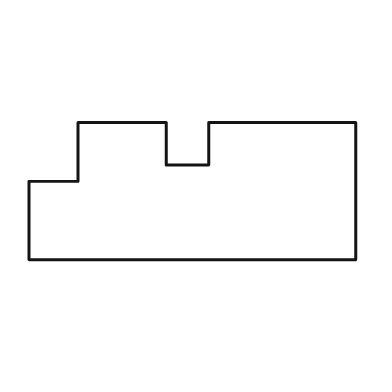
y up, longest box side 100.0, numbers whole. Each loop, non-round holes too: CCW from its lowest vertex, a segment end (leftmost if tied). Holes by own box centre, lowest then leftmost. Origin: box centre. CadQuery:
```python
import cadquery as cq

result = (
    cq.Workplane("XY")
    .moveTo(-50.0, -21.0)
    .lineTo(50.0, -21.0)
    .lineTo(50.0, 21.0)
    .lineTo(5.0, 21.0)
    .lineTo(5.0, 8.0)
    .lineTo(-8.0, 8.0)
    .lineTo(-8.0, 21.0)
    .lineTo(-35.0, 21.0)
    .lineTo(-35.0, 3.0)
    .lineTo(-50.0, 3.0)
    .close()
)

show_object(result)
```